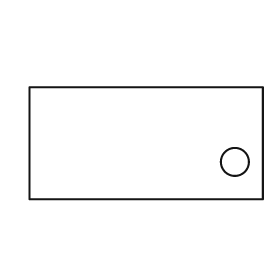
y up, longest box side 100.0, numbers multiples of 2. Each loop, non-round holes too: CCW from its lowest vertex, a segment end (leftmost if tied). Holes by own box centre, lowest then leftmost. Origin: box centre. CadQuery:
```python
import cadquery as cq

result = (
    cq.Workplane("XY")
    .moveTo(-50.0, -24.0)
    .lineTo(50.0, -24.0)
    .lineTo(50.0, 24.0)
    .lineTo(-50.0, 24.0)
    .close()
    .moveTo(38.0, -8.0)
    .circle(6.0)
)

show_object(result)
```